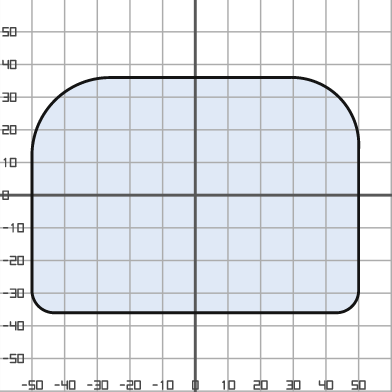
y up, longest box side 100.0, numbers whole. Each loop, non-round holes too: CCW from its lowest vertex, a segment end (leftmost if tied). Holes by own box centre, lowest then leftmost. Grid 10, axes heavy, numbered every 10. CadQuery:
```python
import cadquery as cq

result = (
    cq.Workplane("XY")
    .moveTo(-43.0, -36.0)
    .lineTo(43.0, -36.0)
    .threePointArc((48.0, -34.0), (50.0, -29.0))
    .lineTo(50.0, 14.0)
    .threePointArc((44.0, 30.0), (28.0, 36.0))
    .lineTo(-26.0, 36.0)
    .threePointArc((-43.0, 29.0), (-50.0, 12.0))
    .lineTo(-50.0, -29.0)
    .threePointArc((-48.0, -34.0), (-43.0, -36.0))
    .close()
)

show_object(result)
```